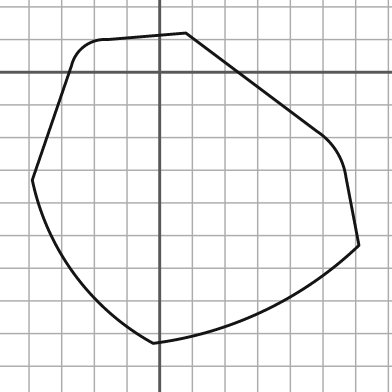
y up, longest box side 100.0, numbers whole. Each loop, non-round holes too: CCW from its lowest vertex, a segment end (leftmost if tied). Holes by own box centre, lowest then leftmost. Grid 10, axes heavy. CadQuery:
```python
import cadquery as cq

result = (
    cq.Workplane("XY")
    .moveTo(-2.0, -83.0)
    .threePointArc((32.0, -73.0), (61.0, -53.0))
    .lineTo(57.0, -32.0)
    .threePointArc((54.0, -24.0), (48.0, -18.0))
    .lineTo(8.0, 12.0)
    .lineTo(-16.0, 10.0)
    .threePointArc((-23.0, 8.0), (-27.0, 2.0))
    .lineTo(-39.0, -33.0)
    .threePointArc((-26.0, -62.0), (-2.0, -83.0))
    .close()
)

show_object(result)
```